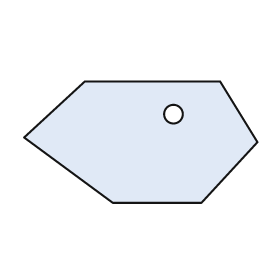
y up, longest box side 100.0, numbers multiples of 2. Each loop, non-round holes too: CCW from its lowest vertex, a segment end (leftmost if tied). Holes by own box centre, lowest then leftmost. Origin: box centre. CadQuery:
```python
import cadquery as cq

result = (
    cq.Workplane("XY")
    .moveTo(-12.0, -26.0)
    .lineTo(26.0, -26.0)
    .lineTo(50.0, 0.0)
    .lineTo(34.0, 26.0)
    .lineTo(-24.0, 26.0)
    .lineTo(-50.0, 2.0)
    .close()
    .moveTo(14.0, 12.0)
    .circle(4.0)
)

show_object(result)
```